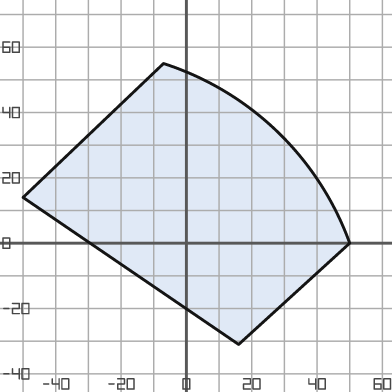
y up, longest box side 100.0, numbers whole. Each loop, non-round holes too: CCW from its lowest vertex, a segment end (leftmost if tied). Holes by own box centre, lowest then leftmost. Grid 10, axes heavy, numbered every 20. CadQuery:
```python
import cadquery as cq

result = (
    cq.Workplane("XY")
    .moveTo(16.0, -31.0)
    .lineTo(50.0, 0.0)
    .threePointArc((28.0, 34.0), (-7.0, 55.0))
    .lineTo(-50.0, 14.0)
    .close()
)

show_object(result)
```